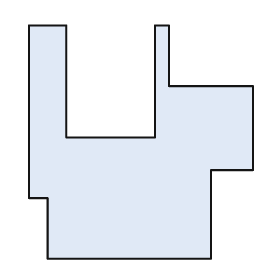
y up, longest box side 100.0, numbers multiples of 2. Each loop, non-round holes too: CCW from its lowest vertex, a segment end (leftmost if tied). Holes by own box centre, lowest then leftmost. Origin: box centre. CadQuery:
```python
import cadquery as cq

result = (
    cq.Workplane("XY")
    .moveTo(-40.0, -50.0)
    .lineTo(30.0, -50.0)
    .lineTo(30.0, -12.0)
    .lineTo(48.0, -12.0)
    .lineTo(48.0, 24.0)
    .lineTo(12.0, 24.0)
    .lineTo(12.0, 50.0)
    .lineTo(6.0, 50.0)
    .lineTo(6.0, 2.0)
    .lineTo(-32.0, 2.0)
    .lineTo(-32.0, 50.0)
    .lineTo(-48.0, 50.0)
    .lineTo(-48.0, -24.0)
    .lineTo(-40.0, -24.0)
    .close()
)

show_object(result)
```